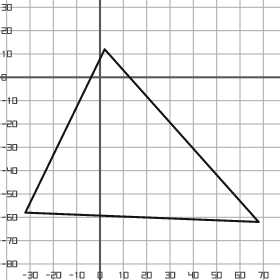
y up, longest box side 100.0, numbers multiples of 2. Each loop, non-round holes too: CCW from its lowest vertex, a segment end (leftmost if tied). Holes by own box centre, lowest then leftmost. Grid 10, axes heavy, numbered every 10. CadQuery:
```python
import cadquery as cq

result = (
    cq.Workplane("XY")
    .moveTo(68.0, -62.0)
    .lineTo(2.0, 12.0)
    .lineTo(-32.0, -58.0)
    .close()
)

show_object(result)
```